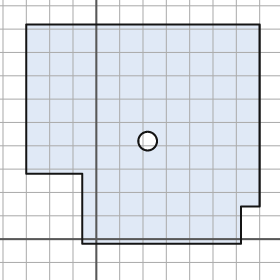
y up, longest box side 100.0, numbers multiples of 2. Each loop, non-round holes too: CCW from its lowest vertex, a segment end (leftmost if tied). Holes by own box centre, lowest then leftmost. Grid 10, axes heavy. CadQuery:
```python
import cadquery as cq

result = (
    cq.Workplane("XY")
    .moveTo(-6.0, -2.0)
    .lineTo(62.0, -2.0)
    .lineTo(62.0, 14.0)
    .lineTo(70.0, 14.0)
    .lineTo(70.0, 92.0)
    .lineTo(-30.0, 92.0)
    .lineTo(-30.0, 28.0)
    .lineTo(-6.0, 28.0)
    .close()
    .moveTo(22.0, 42.0)
    .circle(4.0)
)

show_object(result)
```